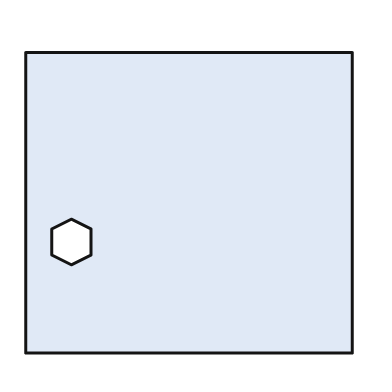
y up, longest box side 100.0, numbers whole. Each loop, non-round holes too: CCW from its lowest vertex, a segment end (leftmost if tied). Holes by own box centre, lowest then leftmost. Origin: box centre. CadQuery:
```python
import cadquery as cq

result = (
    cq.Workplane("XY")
    .moveTo(-50.0, -46.0)
    .lineTo(50.0, -46.0)
    .lineTo(50.0, 46.0)
    .lineTo(-50.0, 46.0)
    .close()
    .moveTo(-36.0, -19.0)
    .lineTo(-30.0, -16.0)
    .lineTo(-30.0, -8.0)
    .lineTo(-36.0, -5.0)
    .lineTo(-42.0, -8.0)
    .lineTo(-42.0, -16.0)
    .close()
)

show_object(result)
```